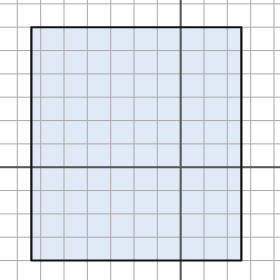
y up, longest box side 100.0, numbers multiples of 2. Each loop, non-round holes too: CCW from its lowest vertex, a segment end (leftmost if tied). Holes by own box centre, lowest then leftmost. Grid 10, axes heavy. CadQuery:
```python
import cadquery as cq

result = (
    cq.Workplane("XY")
    .moveTo(-64.0, -40.0)
    .lineTo(26.0, -40.0)
    .lineTo(26.0, 60.0)
    .lineTo(-64.0, 60.0)
    .close()
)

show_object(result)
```